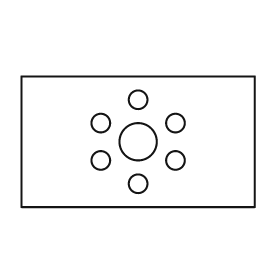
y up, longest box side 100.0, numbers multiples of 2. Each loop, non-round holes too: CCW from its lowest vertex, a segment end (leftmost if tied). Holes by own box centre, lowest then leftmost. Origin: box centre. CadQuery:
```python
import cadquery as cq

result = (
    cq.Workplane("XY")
    .moveTo(-50.0, -28.0)
    .lineTo(50.0, -28.0)
    .lineTo(50.0, 28.0)
    .lineTo(-50.0, 28.0)
    .close()
    .moveTo(0.0, -18.0)
    .circle(4.0)
    .moveTo(-16.0, -8.0)
    .circle(4.0)
    .moveTo(16.0, -8.0)
    .circle(4.0)
    .moveTo(0.0, 0.0)
    .circle(8.0)
    .moveTo(-16.0, 8.0)
    .circle(4.0)
    .moveTo(16.0, 8.0)
    .circle(4.0)
    .moveTo(0.0, 18.0)
    .circle(4.0)
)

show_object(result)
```